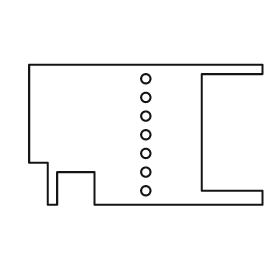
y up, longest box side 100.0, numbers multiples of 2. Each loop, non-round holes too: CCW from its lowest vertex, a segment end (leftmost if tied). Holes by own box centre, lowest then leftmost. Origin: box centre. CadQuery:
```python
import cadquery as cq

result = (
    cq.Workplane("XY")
    .moveTo(-42.0, -30.0)
    .lineTo(-38.0, -30.0)
    .lineTo(-38.0, -16.0)
    .lineTo(-22.0, -16.0)
    .lineTo(-22.0, -30.0)
    .lineTo(50.0, -30.0)
    .lineTo(50.0, -24.0)
    .lineTo(24.0, -24.0)
    .lineTo(24.0, 26.0)
    .lineTo(50.0, 26.0)
    .lineTo(50.0, 30.0)
    .lineTo(-50.0, 30.0)
    .lineTo(-50.0, -12.0)
    .lineTo(-42.0, -12.0)
    .close()
    .moveTo(0.0, -24.0)
    .circle(2.0)
    .moveTo(0.0, -16.0)
    .circle(2.0)
    .moveTo(0.0, -8.0)
    .circle(2.0)
    .moveTo(0.0, 0.0)
    .circle(2.0)
    .moveTo(0.0, 8.0)
    .circle(2.0)
    .moveTo(0.0, 16.0)
    .circle(2.0)
    .moveTo(0.0, 24.0)
    .circle(2.0)
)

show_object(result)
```